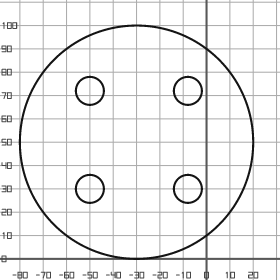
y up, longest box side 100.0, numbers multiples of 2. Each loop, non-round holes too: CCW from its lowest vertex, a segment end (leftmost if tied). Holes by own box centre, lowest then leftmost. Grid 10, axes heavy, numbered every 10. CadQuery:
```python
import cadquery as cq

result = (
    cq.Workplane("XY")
    .moveTo(-30.0, 50.0)
    .circle(50.0)
    .moveTo(-50.0, 30.0)
    .circle(6.0)
    .moveTo(-8.0, 30.0)
    .circle(6.0)
    .moveTo(-50.0, 72.0)
    .circle(6.0)
    .moveTo(-8.0, 72.0)
    .circle(6.0)
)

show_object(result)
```